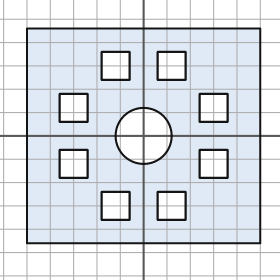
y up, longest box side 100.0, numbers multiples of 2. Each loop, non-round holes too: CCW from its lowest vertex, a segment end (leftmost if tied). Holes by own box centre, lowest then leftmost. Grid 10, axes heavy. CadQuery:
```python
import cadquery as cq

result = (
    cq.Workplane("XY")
    .moveTo(-50.0, -46.0)
    .lineTo(50.0, -46.0)
    .lineTo(50.0, 46.0)
    .lineTo(-50.0, 46.0)
    .close()
    .moveTo(-18.0, -36.0)
    .lineTo(-6.0, -36.0)
    .lineTo(-6.0, -24.0)
    .lineTo(-18.0, -24.0)
    .close()
    .moveTo(6.0, -36.0)
    .lineTo(18.0, -36.0)
    .lineTo(18.0, -24.0)
    .lineTo(6.0, -24.0)
    .close()
    .moveTo(-36.0, -18.0)
    .lineTo(-24.0, -18.0)
    .lineTo(-24.0, -6.0)
    .lineTo(-36.0, -6.0)
    .close()
    .moveTo(24.0, -18.0)
    .lineTo(36.0, -18.0)
    .lineTo(36.0, -6.0)
    .lineTo(24.0, -6.0)
    .close()
    .moveTo(0.0, 0.0)
    .circle(12.0)
    .moveTo(-36.0, 6.0)
    .lineTo(-24.0, 6.0)
    .lineTo(-24.0, 18.0)
    .lineTo(-36.0, 18.0)
    .close()
    .moveTo(24.0, 6.0)
    .lineTo(36.0, 6.0)
    .lineTo(36.0, 18.0)
    .lineTo(24.0, 18.0)
    .close()
    .moveTo(-18.0, 24.0)
    .lineTo(-6.0, 24.0)
    .lineTo(-6.0, 36.0)
    .lineTo(-18.0, 36.0)
    .close()
    .moveTo(6.0, 24.0)
    .lineTo(18.0, 24.0)
    .lineTo(18.0, 36.0)
    .lineTo(6.0, 36.0)
    .close()
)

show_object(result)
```